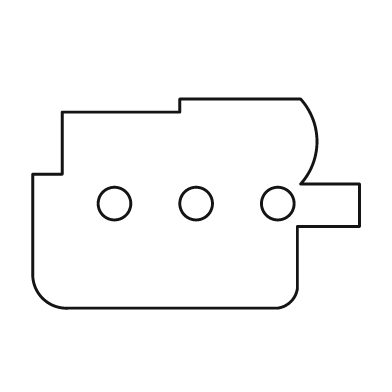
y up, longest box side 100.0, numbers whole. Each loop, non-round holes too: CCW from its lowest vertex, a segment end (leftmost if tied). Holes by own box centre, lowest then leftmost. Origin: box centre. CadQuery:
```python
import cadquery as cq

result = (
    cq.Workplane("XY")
    .moveTo(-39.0, -32.0)
    .lineTo(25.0, -32.0)
    .threePointArc((29.0, -30.0), (31.0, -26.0))
    .lineTo(31.0, -7.0)
    .lineTo(50.0, -7.0)
    .lineTo(50.0, 6.0)
    .lineTo(32.0, 6.0)
    .threePointArc((37.0, 19.0), (32.0, 32.0))
    .lineTo(-5.0, 32.0)
    .lineTo(-5.0, 28.0)
    .lineTo(-41.0, 28.0)
    .lineTo(-41.0, 9.0)
    .lineTo(-50.0, 9.0)
    .lineTo(-50.0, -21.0)
    .threePointArc((-47.0, -29.0), (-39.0, -32.0))
    .close()
    .moveTo(-25.0, 0.0)
    .circle(5.0)
    .moveTo(0.0, 0.0)
    .circle(5.0)
    .moveTo(25.0, 0.0)
    .circle(5.0)
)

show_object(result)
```